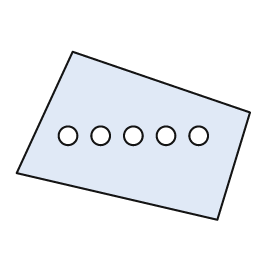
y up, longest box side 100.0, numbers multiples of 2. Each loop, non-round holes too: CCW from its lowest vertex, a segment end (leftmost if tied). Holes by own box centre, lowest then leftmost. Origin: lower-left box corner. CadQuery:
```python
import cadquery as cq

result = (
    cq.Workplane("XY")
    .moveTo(86.0, 0.0)
    .lineTo(100.0, 46.0)
    .lineTo(24.0, 72.0)
    .lineTo(0.0, 20.0)
    .close()
    .moveTo(22.0, 36.0)
    .circle(4.0)
    .moveTo(36.0, 36.0)
    .circle(4.0)
    .moveTo(50.0, 36.0)
    .circle(4.0)
    .moveTo(64.0, 36.0)
    .circle(4.0)
    .moveTo(78.0, 36.0)
    .circle(4.0)
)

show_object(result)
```